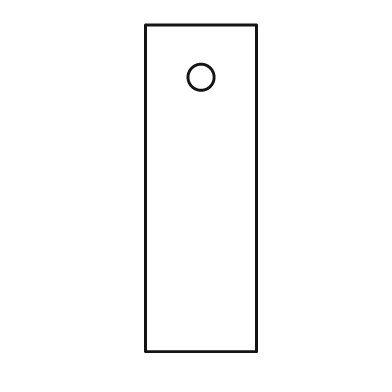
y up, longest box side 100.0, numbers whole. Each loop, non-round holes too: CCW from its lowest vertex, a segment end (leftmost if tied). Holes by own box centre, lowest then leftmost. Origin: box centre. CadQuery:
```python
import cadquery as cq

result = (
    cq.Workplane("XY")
    .moveTo(-17.0, -50.0)
    .lineTo(17.0, -50.0)
    .lineTo(17.0, 50.0)
    .lineTo(-17.0, 50.0)
    .close()
    .moveTo(0.0, 34.0)
    .circle(4.0)
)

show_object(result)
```